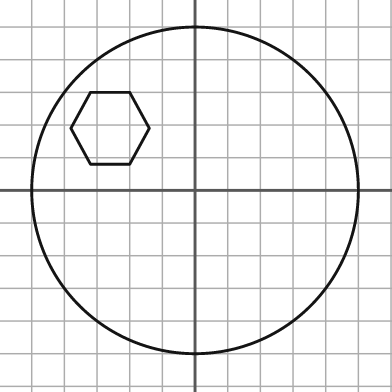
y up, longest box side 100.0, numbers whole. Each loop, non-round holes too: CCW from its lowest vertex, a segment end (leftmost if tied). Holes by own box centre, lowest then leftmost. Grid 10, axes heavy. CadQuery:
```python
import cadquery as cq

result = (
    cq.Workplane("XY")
    .moveTo(0.0, 0.0)
    .circle(50.0)
    .moveTo(-32.0, 8.0)
    .lineTo(-20.0, 8.0)
    .lineTo(-14.0, 19.0)
    .lineTo(-20.0, 30.0)
    .lineTo(-32.0, 30.0)
    .lineTo(-38.0, 19.0)
    .close()
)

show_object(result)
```